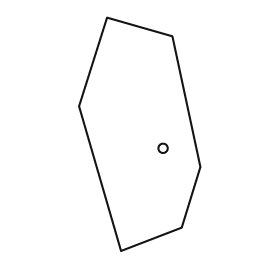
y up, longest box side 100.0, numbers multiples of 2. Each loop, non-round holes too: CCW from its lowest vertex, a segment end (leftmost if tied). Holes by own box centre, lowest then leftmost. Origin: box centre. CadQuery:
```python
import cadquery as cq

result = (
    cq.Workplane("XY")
    .moveTo(-8.0, -50.0)
    .lineTo(18.0, -40.0)
    .lineTo(26.0, -14.0)
    .lineTo(14.0, 42.0)
    .lineTo(-14.0, 50.0)
    .lineTo(-26.0, 12.0)
    .close()
    .moveTo(10.0, -6.0)
    .circle(2.0)
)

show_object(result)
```